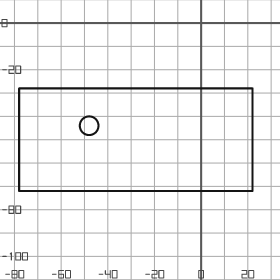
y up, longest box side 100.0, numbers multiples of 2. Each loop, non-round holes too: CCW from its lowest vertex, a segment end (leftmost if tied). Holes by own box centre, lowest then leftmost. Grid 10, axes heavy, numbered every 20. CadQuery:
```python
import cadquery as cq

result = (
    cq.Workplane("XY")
    .moveTo(-78.0, -72.0)
    .lineTo(22.0, -72.0)
    .lineTo(22.0, -28.0)
    .lineTo(-78.0, -28.0)
    .close()
    .moveTo(-48.0, -44.0)
    .circle(4.0)
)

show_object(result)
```